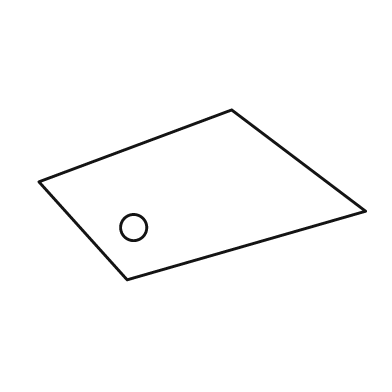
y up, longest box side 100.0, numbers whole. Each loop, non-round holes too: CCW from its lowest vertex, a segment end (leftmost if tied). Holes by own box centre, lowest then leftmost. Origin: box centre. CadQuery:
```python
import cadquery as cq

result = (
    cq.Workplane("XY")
    .moveTo(-23.0, -26.0)
    .lineTo(50.0, -5.0)
    .lineTo(9.0, 26.0)
    .lineTo(-50.0, 4.0)
    .close()
    .moveTo(-21.0, -10.0)
    .circle(4.0)
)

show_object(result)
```